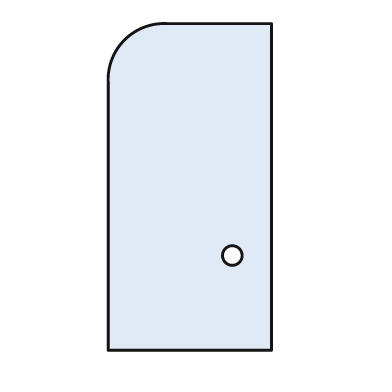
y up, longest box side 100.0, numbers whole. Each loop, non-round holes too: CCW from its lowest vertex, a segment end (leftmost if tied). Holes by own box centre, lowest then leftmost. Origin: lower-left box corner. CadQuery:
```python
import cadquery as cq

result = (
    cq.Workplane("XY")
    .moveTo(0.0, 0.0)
    .lineTo(50.0, 0.0)
    .lineTo(50.0, 100.0)
    .lineTo(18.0, 100.0)
    .threePointArc((5.0, 95.0), (0.0, 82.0))
    .close()
    .moveTo(38.0, 29.0)
    .circle(3.0)
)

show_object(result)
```